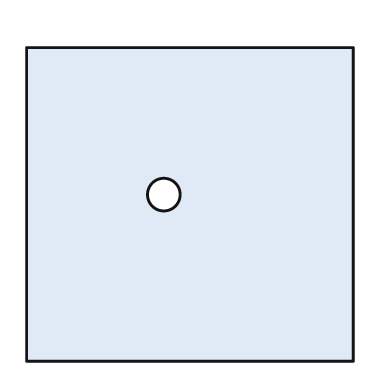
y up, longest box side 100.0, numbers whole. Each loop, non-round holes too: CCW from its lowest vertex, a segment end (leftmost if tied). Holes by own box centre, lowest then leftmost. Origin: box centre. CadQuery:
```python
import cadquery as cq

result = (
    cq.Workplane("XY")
    .moveTo(-50.0, -48.0)
    .lineTo(50.0, -48.0)
    .lineTo(50.0, 48.0)
    .lineTo(-50.0, 48.0)
    .close()
    .moveTo(-8.0, 3.0)
    .circle(5.0)
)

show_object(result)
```